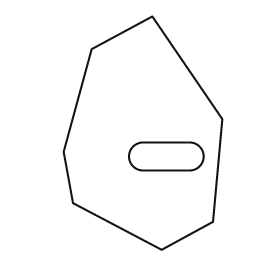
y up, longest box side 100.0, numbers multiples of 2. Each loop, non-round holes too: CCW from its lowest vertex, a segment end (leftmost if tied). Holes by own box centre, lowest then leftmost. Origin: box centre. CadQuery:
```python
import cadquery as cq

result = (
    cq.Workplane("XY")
    .moveTo(8.0, -50.0)
    .lineTo(30.0, -38.0)
    .lineTo(34.0, 6.0)
    .lineTo(4.0, 50.0)
    .lineTo(-22.0, 36.0)
    .lineTo(-34.0, -8.0)
    .lineTo(-30.0, -30.0)
    .close()
    .moveTo(0.0, -16.0)
    .lineTo(20.0, -16.0)
    .threePointArc((26.0, -10.0), (20.0, -4.0))
    .lineTo(0.0, -4.0)
    .threePointArc((-6.0, -10.0), (0.0, -16.0))
    .close()
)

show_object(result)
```